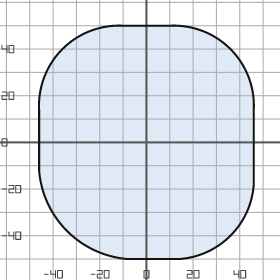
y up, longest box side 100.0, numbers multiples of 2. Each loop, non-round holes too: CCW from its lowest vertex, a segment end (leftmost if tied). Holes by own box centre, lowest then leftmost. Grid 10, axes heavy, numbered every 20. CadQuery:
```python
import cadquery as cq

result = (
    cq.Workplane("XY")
    .moveTo(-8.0, -50.0)
    .lineTo(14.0, -50.0)
    .threePointArc((36.0, -40.0), (46.0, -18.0))
    .lineTo(46.0, 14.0)
    .threePointArc((36.0, 40.0), (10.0, 50.0))
    .lineTo(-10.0, 50.0)
    .threePointArc((-36.0, 40.0), (-46.0, 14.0))
    .lineTo(-46.0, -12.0)
    .threePointArc((-34.0, -38.0), (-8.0, -50.0))
    .close()
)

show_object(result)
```